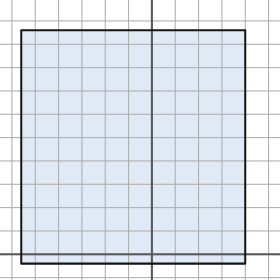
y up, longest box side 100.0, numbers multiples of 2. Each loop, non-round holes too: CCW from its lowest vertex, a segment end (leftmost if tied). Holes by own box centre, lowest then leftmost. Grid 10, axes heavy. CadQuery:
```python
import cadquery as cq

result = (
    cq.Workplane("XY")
    .moveTo(-56.0, -4.0)
    .lineTo(40.0, -4.0)
    .lineTo(40.0, 96.0)
    .lineTo(-56.0, 96.0)
    .close()
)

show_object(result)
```